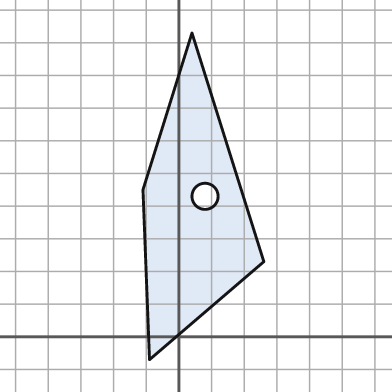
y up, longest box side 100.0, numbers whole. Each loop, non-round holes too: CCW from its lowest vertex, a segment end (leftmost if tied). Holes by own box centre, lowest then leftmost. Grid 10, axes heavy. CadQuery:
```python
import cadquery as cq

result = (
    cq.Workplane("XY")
    .moveTo(-9.0, -7.0)
    .lineTo(26.0, 23.0)
    .lineTo(4.0, 93.0)
    .lineTo(-11.0, 45.0)
    .close()
    .moveTo(8.0, 43.0)
    .circle(4.0)
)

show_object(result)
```